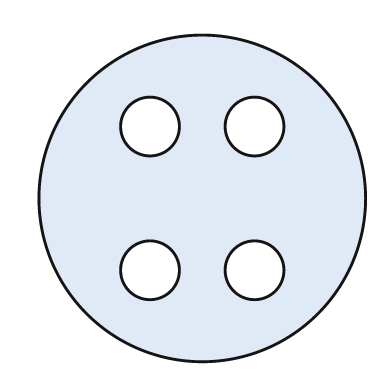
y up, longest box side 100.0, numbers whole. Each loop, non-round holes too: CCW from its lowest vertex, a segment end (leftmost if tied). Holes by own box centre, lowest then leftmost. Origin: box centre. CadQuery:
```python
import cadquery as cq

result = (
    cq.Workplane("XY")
    .moveTo(0.0, 0.0)
    .circle(50.0)
    .moveTo(-16.0, -22.0)
    .circle(9.0)
    .moveTo(16.0, -22.0)
    .circle(9.0)
    .moveTo(-16.0, 22.0)
    .circle(9.0)
    .moveTo(16.0, 22.0)
    .circle(9.0)
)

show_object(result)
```